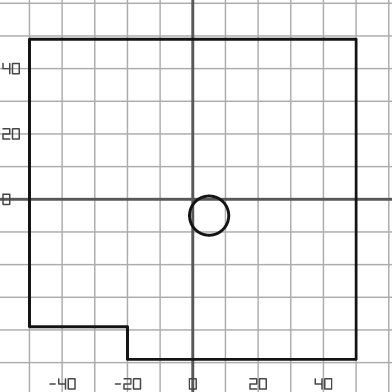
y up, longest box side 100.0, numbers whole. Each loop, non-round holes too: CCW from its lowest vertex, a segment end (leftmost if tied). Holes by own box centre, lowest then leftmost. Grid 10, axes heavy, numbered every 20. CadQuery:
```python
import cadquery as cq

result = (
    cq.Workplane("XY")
    .moveTo(-20.0, -49.0)
    .lineTo(50.0, -49.0)
    .lineTo(50.0, 49.0)
    .lineTo(-50.0, 49.0)
    .lineTo(-50.0, -39.0)
    .lineTo(-20.0, -39.0)
    .close()
    .moveTo(5.0, -5.0)
    .circle(6.0)
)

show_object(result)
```